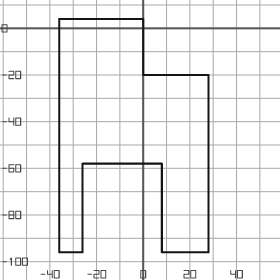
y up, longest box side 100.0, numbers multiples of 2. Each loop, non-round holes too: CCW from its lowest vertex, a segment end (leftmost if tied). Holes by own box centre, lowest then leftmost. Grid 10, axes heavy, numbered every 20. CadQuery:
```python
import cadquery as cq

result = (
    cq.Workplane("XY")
    .moveTo(-36.0, -96.0)
    .lineTo(-26.0, -96.0)
    .lineTo(-26.0, -58.0)
    .lineTo(8.0, -58.0)
    .lineTo(8.0, -96.0)
    .lineTo(28.0, -96.0)
    .lineTo(28.0, -20.0)
    .lineTo(0.0, -20.0)
    .lineTo(0.0, 4.0)
    .lineTo(-36.0, 4.0)
    .close()
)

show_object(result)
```